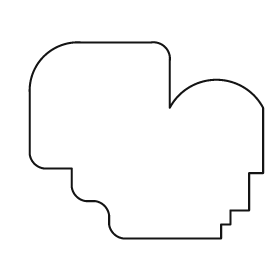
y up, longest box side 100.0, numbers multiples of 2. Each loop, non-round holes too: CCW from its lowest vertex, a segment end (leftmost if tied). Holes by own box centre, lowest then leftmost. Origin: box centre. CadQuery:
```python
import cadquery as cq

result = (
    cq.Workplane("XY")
    .moveTo(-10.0, -42.0)
    .lineTo(32.0, -42.0)
    .lineTo(32.0, -36.0)
    .lineTo(36.0, -36.0)
    .lineTo(36.0, -30.0)
    .lineTo(44.0, -30.0)
    .lineTo(44.0, -14.0)
    .lineTo(50.0, -14.0)
    .lineTo(50.0, 14.0)
    .threePointArc((30.0, 26.0), (10.0, 14.0))
    .lineTo(10.0, 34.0)
    .threePointArc((8.0, 40.0), (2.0, 42.0))
    .lineTo(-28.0, 42.0)
    .threePointArc((-44.0, 36.0), (-50.0, 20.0))
    .lineTo(-50.0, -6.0)
    .threePointArc((-48.0, -10.0), (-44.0, -12.0))
    .lineTo(-32.0, -12.0)
    .lineTo(-32.0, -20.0)
    .threePointArc((-30.0, -24.0), (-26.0, -26.0))
    .lineTo(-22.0, -26.0)
    .threePointArc((-18.0, -28.0), (-16.0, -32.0))
    .lineTo(-16.0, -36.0)
    .threePointArc((-14.0, -40.0), (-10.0, -42.0))
    .close()
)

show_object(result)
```